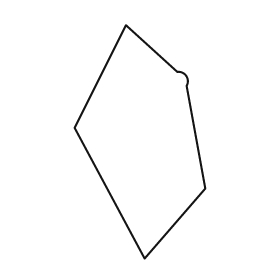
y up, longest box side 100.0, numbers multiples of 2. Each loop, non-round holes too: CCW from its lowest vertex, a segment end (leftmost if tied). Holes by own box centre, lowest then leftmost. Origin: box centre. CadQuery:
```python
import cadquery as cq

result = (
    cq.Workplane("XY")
    .moveTo(2.0, -50.0)
    .lineTo(28.0, -20.0)
    .lineTo(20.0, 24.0)
    .threePointArc((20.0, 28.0), (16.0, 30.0))
    .lineTo(-6.0, 50.0)
    .lineTo(-28.0, 6.0)
    .close()
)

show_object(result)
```